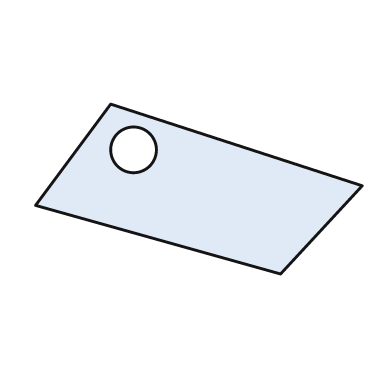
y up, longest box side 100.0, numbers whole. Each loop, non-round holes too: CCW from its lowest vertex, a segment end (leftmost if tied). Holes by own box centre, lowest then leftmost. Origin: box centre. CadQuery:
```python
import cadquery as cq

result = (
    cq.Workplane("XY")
    .moveTo(25.0, -26.0)
    .lineTo(50.0, 1.0)
    .lineTo(-27.0, 26.0)
    .lineTo(-50.0, -5.0)
    .close()
    .moveTo(-20.0, 12.0)
    .circle(7.0)
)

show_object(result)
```